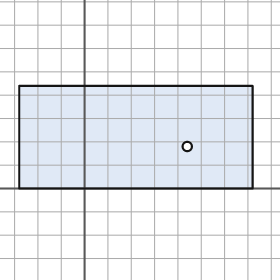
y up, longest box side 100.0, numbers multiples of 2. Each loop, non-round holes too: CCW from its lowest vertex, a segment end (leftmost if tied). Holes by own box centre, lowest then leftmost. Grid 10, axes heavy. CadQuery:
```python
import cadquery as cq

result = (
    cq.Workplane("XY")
    .moveTo(-28.0, 0.0)
    .lineTo(72.0, 0.0)
    .lineTo(72.0, 44.0)
    .lineTo(-28.0, 44.0)
    .close()
    .moveTo(44.0, 18.0)
    .circle(2.0)
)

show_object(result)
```